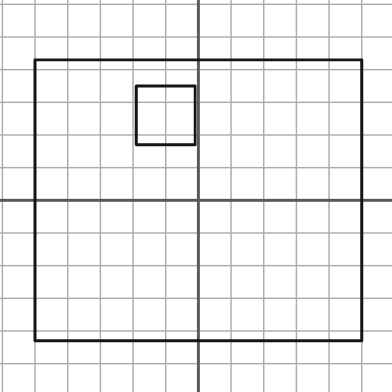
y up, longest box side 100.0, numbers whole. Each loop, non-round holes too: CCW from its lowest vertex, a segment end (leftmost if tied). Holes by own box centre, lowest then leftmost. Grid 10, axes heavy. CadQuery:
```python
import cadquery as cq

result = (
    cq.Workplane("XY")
    .moveTo(-50.0, -43.0)
    .lineTo(50.0, -43.0)
    .lineTo(50.0, 43.0)
    .lineTo(-50.0, 43.0)
    .close()
    .moveTo(-19.0, 17.0)
    .lineTo(-1.0, 17.0)
    .lineTo(-1.0, 35.0)
    .lineTo(-19.0, 35.0)
    .close()
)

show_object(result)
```